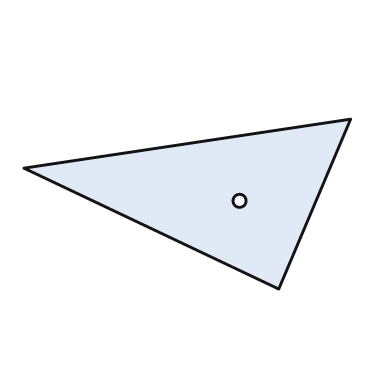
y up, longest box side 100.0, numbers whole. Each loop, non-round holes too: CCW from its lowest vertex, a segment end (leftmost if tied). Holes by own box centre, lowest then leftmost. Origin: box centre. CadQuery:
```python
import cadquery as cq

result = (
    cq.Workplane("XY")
    .moveTo(28.0, -26.0)
    .lineTo(50.0, 26.0)
    .lineTo(-50.0, 11.0)
    .close()
    .moveTo(16.0, 1.0)
    .circle(2.0)
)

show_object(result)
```